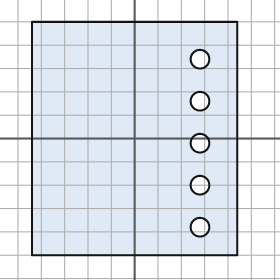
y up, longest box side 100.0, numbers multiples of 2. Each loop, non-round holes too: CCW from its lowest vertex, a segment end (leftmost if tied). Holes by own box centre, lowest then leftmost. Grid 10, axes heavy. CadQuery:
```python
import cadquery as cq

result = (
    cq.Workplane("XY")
    .moveTo(-44.0, -50.0)
    .lineTo(44.0, -50.0)
    .lineTo(44.0, 50.0)
    .lineTo(-44.0, 50.0)
    .close()
    .moveTo(28.0, -38.0)
    .circle(4.0)
    .moveTo(28.0, -20.0)
    .circle(4.0)
    .moveTo(28.0, -2.0)
    .circle(4.0)
    .moveTo(28.0, 16.0)
    .circle(4.0)
    .moveTo(28.0, 34.0)
    .circle(4.0)
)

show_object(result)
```